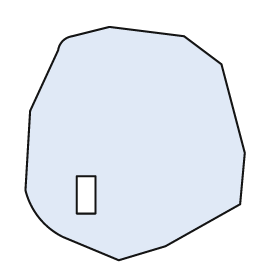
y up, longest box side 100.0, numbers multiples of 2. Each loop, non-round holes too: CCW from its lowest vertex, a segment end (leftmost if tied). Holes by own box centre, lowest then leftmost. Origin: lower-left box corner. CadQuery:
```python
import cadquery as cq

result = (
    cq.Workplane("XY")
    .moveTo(40.0, 0.0)
    .lineTo(60.0, 6.0)
    .lineTo(92.0, 24.0)
    .lineTo(94.0, 46.0)
    .lineTo(84.0, 84.0)
    .lineTo(68.0, 96.0)
    .lineTo(36.0, 100.0)
    .lineTo(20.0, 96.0)
    .threePointArc((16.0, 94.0), (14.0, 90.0))
    .lineTo(2.0, 64.0)
    .lineTo(0.0, 30.0)
    .threePointArc((6.0, 18.0), (16.0, 10.0))
    .close()
    .moveTo(22.0, 20.0)
    .lineTo(30.0, 20.0)
    .lineTo(30.0, 36.0)
    .lineTo(22.0, 36.0)
    .close()
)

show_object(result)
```